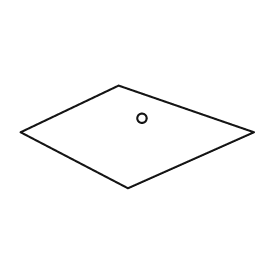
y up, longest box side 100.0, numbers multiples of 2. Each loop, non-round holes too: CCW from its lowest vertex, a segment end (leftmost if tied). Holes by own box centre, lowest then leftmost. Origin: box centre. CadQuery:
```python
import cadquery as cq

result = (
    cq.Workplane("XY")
    .moveTo(-4.0, -22.0)
    .lineTo(50.0, 2.0)
    .lineTo(-8.0, 22.0)
    .lineTo(-50.0, 2.0)
    .close()
    .moveTo(2.0, 8.0)
    .circle(2.0)
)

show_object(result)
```